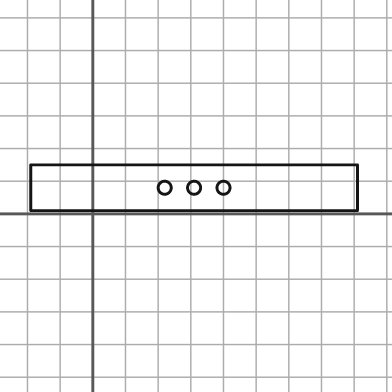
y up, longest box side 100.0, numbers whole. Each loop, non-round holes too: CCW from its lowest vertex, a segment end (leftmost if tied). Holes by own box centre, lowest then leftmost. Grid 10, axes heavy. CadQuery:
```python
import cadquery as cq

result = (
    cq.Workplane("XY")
    .moveTo(-19.0, 1.0)
    .lineTo(81.0, 1.0)
    .lineTo(81.0, 15.0)
    .lineTo(-19.0, 15.0)
    .close()
    .moveTo(22.0, 8.0)
    .circle(2.0)
    .moveTo(31.0, 8.0)
    .circle(2.0)
    .moveTo(40.0, 8.0)
    .circle(2.0)
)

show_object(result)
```